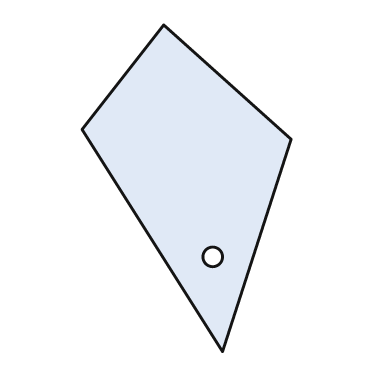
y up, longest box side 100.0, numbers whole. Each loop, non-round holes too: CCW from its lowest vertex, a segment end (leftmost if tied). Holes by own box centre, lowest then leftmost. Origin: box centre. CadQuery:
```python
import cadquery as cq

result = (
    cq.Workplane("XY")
    .moveTo(11.0, -50.0)
    .lineTo(32.0, 15.0)
    .lineTo(-7.0, 50.0)
    .lineTo(-32.0, 18.0)
    .close()
    .moveTo(8.0, -21.0)
    .circle(3.0)
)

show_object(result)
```